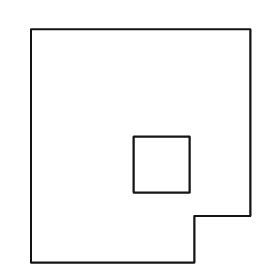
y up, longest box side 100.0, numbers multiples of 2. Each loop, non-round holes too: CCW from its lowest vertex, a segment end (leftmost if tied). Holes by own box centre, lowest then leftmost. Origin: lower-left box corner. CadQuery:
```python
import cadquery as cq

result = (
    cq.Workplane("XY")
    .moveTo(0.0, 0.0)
    .lineTo(70.0, 0.0)
    .lineTo(70.0, 20.0)
    .lineTo(94.0, 20.0)
    .lineTo(94.0, 100.0)
    .lineTo(0.0, 100.0)
    .close()
    .moveTo(44.0, 30.0)
    .lineTo(68.0, 30.0)
    .lineTo(68.0, 54.0)
    .lineTo(44.0, 54.0)
    .close()
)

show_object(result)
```